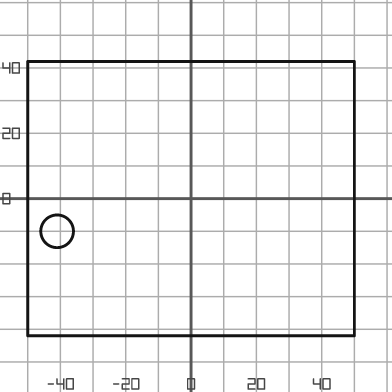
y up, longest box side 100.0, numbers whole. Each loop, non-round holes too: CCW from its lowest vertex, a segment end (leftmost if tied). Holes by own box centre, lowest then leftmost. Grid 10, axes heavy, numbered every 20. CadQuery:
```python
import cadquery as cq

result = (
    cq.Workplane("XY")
    .moveTo(-50.0, -42.0)
    .lineTo(50.0, -42.0)
    .lineTo(50.0, 42.0)
    .lineTo(-50.0, 42.0)
    .close()
    .moveTo(-41.0, -10.0)
    .circle(5.0)
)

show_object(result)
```